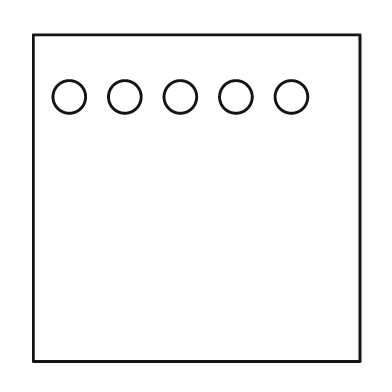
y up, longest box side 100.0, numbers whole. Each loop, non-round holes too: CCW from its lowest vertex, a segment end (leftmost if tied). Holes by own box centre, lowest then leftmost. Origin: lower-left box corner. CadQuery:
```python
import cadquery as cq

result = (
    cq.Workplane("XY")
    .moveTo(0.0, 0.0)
    .lineTo(100.0, 0.0)
    .lineTo(100.0, 100.0)
    .lineTo(0.0, 100.0)
    .close()
    .moveTo(11.0, 81.0)
    .circle(5.0)
    .moveTo(28.0, 81.0)
    .circle(5.0)
    .moveTo(45.0, 81.0)
    .circle(5.0)
    .moveTo(62.0, 81.0)
    .circle(5.0)
    .moveTo(79.0, 81.0)
    .circle(5.0)
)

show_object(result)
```